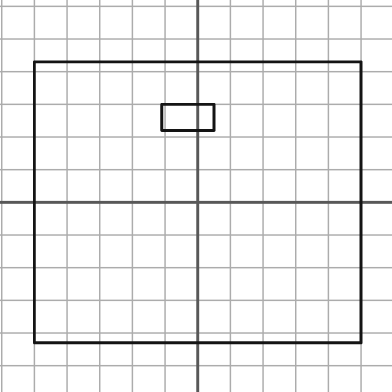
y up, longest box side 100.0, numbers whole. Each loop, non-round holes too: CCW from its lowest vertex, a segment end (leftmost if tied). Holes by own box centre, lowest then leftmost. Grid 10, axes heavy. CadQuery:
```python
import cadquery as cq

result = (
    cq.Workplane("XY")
    .moveTo(-50.0, -43.0)
    .lineTo(50.0, -43.0)
    .lineTo(50.0, 43.0)
    .lineTo(-50.0, 43.0)
    .close()
    .moveTo(-11.0, 22.0)
    .lineTo(5.0, 22.0)
    .lineTo(5.0, 30.0)
    .lineTo(-11.0, 30.0)
    .close()
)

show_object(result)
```